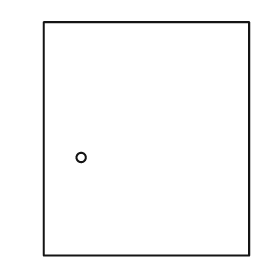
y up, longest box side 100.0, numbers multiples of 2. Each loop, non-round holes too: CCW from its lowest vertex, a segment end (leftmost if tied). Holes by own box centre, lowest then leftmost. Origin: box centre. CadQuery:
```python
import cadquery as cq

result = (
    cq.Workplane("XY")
    .moveTo(-44.0, -50.0)
    .lineTo(44.0, -50.0)
    .lineTo(44.0, 50.0)
    .lineTo(-44.0, 50.0)
    .close()
    .moveTo(-28.0, -8.0)
    .circle(2.0)
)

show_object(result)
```